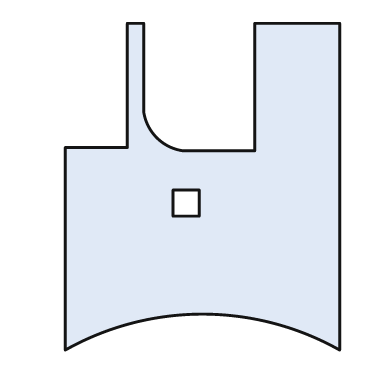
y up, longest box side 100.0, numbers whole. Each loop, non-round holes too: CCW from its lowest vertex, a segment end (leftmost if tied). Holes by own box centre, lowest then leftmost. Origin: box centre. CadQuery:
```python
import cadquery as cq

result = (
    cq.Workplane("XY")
    .moveTo(-42.0, -50.0)
    .threePointArc((0.0, -39.0), (42.0, -50.0))
    .lineTo(42.0, 50.0)
    .lineTo(16.0, 50.0)
    .lineTo(16.0, 11.0)
    .lineTo(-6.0, 11.0)
    .threePointArc((-14.0, 15.0), (-18.0, 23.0))
    .lineTo(-18.0, 50.0)
    .lineTo(-23.0, 50.0)
    .lineTo(-23.0, 12.0)
    .lineTo(-42.0, 12.0)
    .close()
    .moveTo(-9.0, -9.0)
    .lineTo(-1.0, -9.0)
    .lineTo(-1.0, -1.0)
    .lineTo(-9.0, -1.0)
    .close()
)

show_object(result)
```